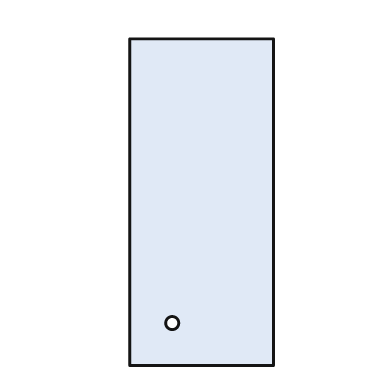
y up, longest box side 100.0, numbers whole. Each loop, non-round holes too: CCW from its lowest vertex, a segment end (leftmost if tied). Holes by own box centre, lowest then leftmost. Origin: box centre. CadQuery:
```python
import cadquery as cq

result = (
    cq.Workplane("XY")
    .moveTo(-22.0, -50.0)
    .lineTo(22.0, -50.0)
    .lineTo(22.0, 50.0)
    .lineTo(-22.0, 50.0)
    .close()
    .moveTo(-9.0, -37.0)
    .circle(2.0)
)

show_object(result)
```